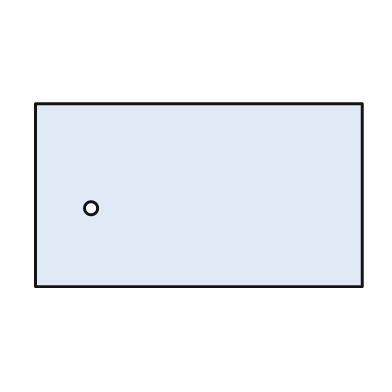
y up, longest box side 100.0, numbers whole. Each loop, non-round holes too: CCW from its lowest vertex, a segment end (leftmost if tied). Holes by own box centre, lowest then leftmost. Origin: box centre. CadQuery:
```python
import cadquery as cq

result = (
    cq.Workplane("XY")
    .moveTo(-50.0, -28.0)
    .lineTo(50.0, -28.0)
    .lineTo(50.0, 28.0)
    .lineTo(-50.0, 28.0)
    .close()
    .moveTo(-33.0, -4.0)
    .circle(2.0)
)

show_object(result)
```